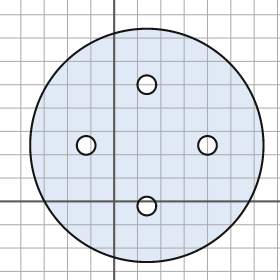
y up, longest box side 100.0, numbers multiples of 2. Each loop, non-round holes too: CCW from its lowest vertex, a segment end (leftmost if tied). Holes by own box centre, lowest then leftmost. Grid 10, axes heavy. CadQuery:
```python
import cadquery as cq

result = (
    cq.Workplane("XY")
    .moveTo(14.0, 24.0)
    .circle(50.0)
    .moveTo(14.0, -2.0)
    .circle(4.0)
    .moveTo(-12.0, 24.0)
    .circle(4.0)
    .moveTo(40.0, 24.0)
    .circle(4.0)
    .moveTo(14.0, 50.0)
    .circle(4.0)
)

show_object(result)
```